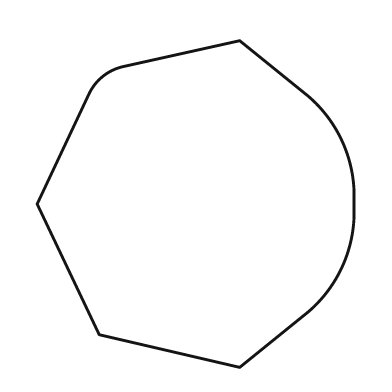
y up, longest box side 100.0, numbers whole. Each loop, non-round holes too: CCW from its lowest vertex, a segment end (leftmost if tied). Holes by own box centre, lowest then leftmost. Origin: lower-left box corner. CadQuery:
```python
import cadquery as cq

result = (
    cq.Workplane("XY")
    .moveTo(62.0, 0.0)
    .lineTo(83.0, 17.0)
    .threePointArc((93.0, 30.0), (97.0, 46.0))
    .lineTo(97.0, 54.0)
    .threePointArc((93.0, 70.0), (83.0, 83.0))
    .lineTo(62.0, 100.0)
    .lineTo(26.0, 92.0)
    .threePointArc((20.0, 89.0), (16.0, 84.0))
    .lineTo(0.0, 50.0)
    .lineTo(19.0, 10.0)
    .close()
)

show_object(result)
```